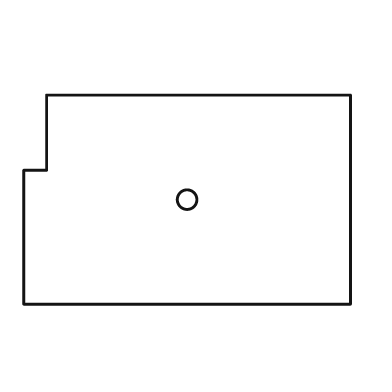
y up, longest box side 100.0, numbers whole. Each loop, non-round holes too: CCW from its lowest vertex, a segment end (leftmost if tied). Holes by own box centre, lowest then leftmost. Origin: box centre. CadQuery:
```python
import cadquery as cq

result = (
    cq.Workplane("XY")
    .moveTo(-50.0, -32.0)
    .lineTo(50.0, -32.0)
    .lineTo(50.0, 32.0)
    .lineTo(-43.0, 32.0)
    .lineTo(-43.0, 9.0)
    .lineTo(-50.0, 9.0)
    .close()
    .moveTo(0.0, 0.0)
    .circle(3.0)
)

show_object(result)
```